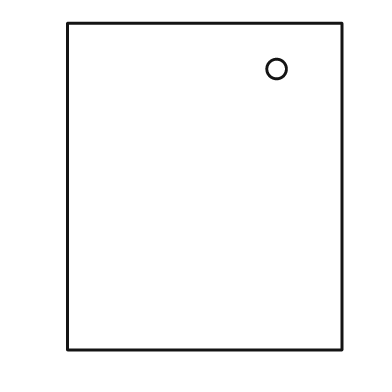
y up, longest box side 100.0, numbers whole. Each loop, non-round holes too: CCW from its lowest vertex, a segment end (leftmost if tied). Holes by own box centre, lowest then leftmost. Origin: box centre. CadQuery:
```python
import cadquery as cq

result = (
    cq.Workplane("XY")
    .moveTo(-42.0, -50.0)
    .lineTo(42.0, -50.0)
    .lineTo(42.0, 50.0)
    .lineTo(-42.0, 50.0)
    .close()
    .moveTo(22.0, 36.0)
    .circle(3.0)
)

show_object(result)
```